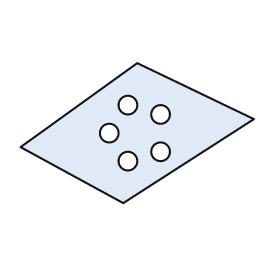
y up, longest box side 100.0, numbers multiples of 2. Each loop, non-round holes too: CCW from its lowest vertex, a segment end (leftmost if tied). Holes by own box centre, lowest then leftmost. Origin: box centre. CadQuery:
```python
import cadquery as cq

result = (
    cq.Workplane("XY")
    .moveTo(-6.0, -30.0)
    .lineTo(50.0, 6.0)
    .lineTo(0.0, 30.0)
    .lineTo(-50.0, -6.0)
    .close()
    .moveTo(-4.0, -12.0)
    .circle(4.0)
    .moveTo(10.0, -8.0)
    .circle(4.0)
    .moveTo(-12.0, 0.0)
    .circle(4.0)
    .moveTo(10.0, 8.0)
    .circle(4.0)
    .moveTo(-4.0, 12.0)
    .circle(4.0)
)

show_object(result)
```